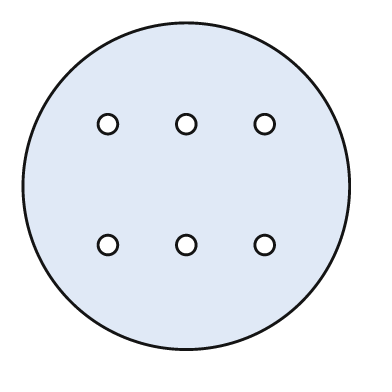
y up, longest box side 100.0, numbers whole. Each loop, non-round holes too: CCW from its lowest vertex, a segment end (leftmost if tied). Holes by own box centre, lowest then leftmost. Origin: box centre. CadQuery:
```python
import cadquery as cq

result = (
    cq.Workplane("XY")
    .moveTo(0.0, 0.0)
    .circle(50.0)
    .moveTo(-24.0, -18.0)
    .circle(3.0)
    .moveTo(0.0, -18.0)
    .circle(3.0)
    .moveTo(24.0, -18.0)
    .circle(3.0)
    .moveTo(-24.0, 19.0)
    .circle(3.0)
    .moveTo(0.0, 19.0)
    .circle(3.0)
    .moveTo(24.0, 19.0)
    .circle(3.0)
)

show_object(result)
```